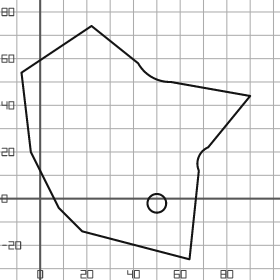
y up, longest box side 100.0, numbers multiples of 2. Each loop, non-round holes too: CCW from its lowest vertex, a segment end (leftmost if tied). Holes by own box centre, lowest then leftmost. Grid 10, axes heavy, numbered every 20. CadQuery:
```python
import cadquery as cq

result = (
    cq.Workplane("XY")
    .moveTo(64.0, -26.0)
    .lineTo(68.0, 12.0)
    .threePointArc((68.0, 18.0), (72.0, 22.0))
    .lineTo(90.0, 44.0)
    .lineTo(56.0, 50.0)
    .threePointArc((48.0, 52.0), (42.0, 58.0))
    .lineTo(22.0, 74.0)
    .lineTo(-8.0, 54.0)
    .lineTo(-4.0, 20.0)
    .lineTo(8.0, -4.0)
    .lineTo(18.0, -14.0)
    .close()
    .moveTo(50.0, -2.0)
    .circle(4.0)
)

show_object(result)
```